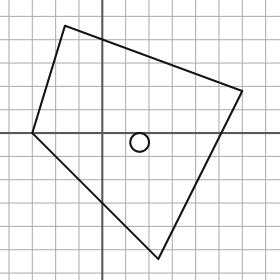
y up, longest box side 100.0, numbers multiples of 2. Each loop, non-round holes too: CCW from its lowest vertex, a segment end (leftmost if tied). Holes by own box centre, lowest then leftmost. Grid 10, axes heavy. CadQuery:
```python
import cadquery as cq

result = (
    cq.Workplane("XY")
    .moveTo(24.0, -54.0)
    .lineTo(60.0, 18.0)
    .lineTo(-16.0, 46.0)
    .lineTo(-30.0, 0.0)
    .close()
    .moveTo(16.0, -4.0)
    .circle(4.0)
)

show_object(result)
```